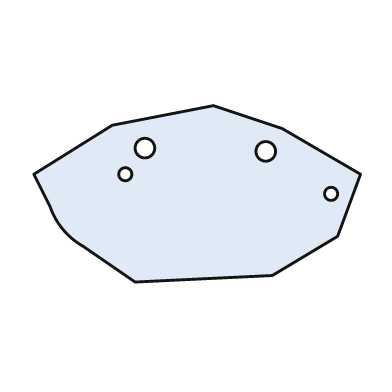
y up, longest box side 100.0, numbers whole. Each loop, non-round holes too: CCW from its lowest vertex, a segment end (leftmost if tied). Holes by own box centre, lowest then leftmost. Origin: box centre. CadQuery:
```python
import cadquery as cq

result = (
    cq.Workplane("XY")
    .moveTo(-19.0, -27.0)
    .lineTo(23.0, -25.0)
    .lineTo(43.0, -13.0)
    .lineTo(50.0, 6.0)
    .lineTo(26.0, 20.0)
    .lineTo(5.0, 27.0)
    .lineTo(-26.0, 21.0)
    .lineTo(-50.0, 6.0)
    .lineTo(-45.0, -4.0)
    .threePointArc((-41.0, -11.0), (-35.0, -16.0))
    .close()
    .moveTo(41.0, 0.0)
    .circle(2.0)
    .moveTo(-22.0, 6.0)
    .circle(2.0)
    .moveTo(21.0, 13.0)
    .circle(3.0)
    .moveTo(-16.0, 14.0)
    .circle(3.0)
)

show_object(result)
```